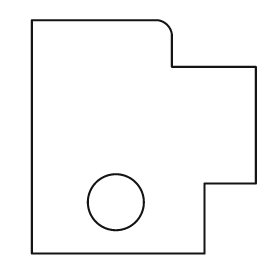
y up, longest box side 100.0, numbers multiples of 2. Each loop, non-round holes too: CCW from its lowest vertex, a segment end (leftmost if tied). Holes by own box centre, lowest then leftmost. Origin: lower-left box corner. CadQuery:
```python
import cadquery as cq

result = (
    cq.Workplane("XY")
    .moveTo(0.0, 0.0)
    .lineTo(74.0, 0.0)
    .lineTo(74.0, 30.0)
    .lineTo(96.0, 30.0)
    .lineTo(96.0, 80.0)
    .lineTo(60.0, 80.0)
    .lineTo(60.0, 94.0)
    .threePointArc((58.0, 98.0), (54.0, 100.0))
    .lineTo(0.0, 100.0)
    .close()
    .moveTo(36.0, 22.0)
    .circle(12.0)
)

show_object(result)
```